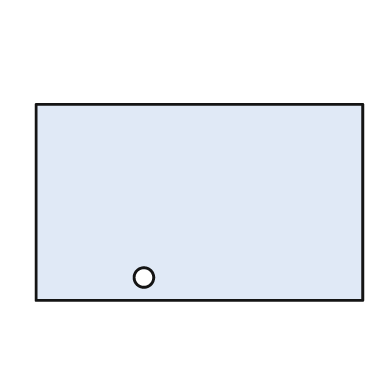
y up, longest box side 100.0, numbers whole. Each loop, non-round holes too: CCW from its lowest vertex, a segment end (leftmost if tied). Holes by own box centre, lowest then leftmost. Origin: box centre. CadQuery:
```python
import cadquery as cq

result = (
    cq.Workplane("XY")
    .moveTo(-50.0, -30.0)
    .lineTo(50.0, -30.0)
    .lineTo(50.0, 30.0)
    .lineTo(-50.0, 30.0)
    .close()
    .moveTo(-17.0, -23.0)
    .circle(3.0)
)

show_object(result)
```